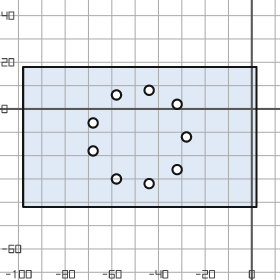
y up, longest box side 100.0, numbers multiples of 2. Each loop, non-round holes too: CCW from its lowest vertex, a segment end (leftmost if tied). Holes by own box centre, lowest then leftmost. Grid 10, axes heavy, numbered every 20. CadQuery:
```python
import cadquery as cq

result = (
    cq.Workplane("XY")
    .moveTo(-98.0, -42.0)
    .lineTo(2.0, -42.0)
    .lineTo(2.0, 18.0)
    .lineTo(-98.0, 18.0)
    .close()
    .moveTo(-44.0, -32.0)
    .circle(2.0)
    .moveTo(-58.0, -30.0)
    .circle(2.0)
    .moveTo(-32.0, -26.0)
    .circle(2.0)
    .moveTo(-68.0, -18.0)
    .circle(2.0)
    .moveTo(-28.0, -12.0)
    .circle(2.0)
    .moveTo(-68.0, -6.0)
    .circle(2.0)
    .moveTo(-32.0, 2.0)
    .circle(2.0)
    .moveTo(-58.0, 6.0)
    .circle(2.0)
    .moveTo(-44.0, 8.0)
    .circle(2.0)
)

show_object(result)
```